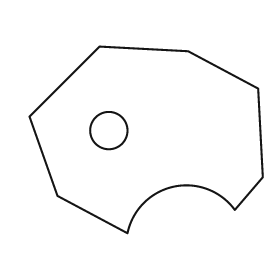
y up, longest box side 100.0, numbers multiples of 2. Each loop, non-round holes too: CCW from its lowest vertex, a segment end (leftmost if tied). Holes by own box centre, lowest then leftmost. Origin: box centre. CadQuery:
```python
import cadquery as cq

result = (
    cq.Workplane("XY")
    .moveTo(-8.0, -40.0)
    .threePointArc((12.0, -20.0), (38.0, -30.0))
    .lineTo(50.0, -16.0)
    .lineTo(48.0, 22.0)
    .lineTo(18.0, 38.0)
    .lineTo(-20.0, 40.0)
    .lineTo(-50.0, 10.0)
    .lineTo(-38.0, -24.0)
    .close()
    .moveTo(-16.0, 4.0)
    .circle(8.0)
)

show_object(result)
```